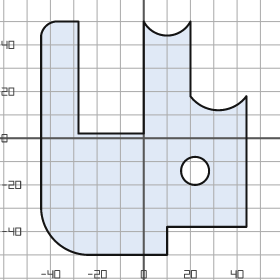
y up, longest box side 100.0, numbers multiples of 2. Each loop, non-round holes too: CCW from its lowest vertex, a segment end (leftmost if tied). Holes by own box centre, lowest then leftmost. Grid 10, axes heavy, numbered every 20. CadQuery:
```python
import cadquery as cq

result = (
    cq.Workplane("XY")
    .moveTo(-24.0, -50.0)
    .lineTo(10.0, -50.0)
    .lineTo(10.0, -38.0)
    .lineTo(44.0, -38.0)
    .lineTo(44.0, 18.0)
    .threePointArc((32.0, 12.0), (20.0, 18.0))
    .lineTo(20.0, 50.0)
    .threePointArc((10.0, 44.0), (0.0, 50.0))
    .lineTo(0.0, 2.0)
    .lineTo(-28.0, 2.0)
    .lineTo(-28.0, 50.0)
    .lineTo(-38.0, 50.0)
    .threePointArc((-42.0, 48.0), (-44.0, 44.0))
    .lineTo(-44.0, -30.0)
    .threePointArc((-38.0, -44.0), (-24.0, -50.0))
    .close()
    .moveTo(22.0, -14.0)
    .circle(6.0)
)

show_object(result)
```